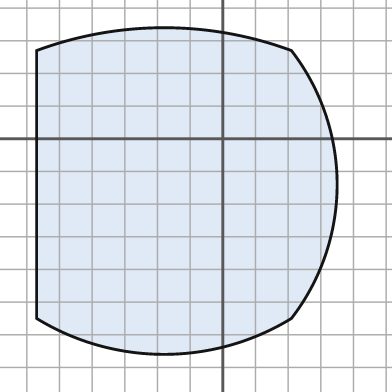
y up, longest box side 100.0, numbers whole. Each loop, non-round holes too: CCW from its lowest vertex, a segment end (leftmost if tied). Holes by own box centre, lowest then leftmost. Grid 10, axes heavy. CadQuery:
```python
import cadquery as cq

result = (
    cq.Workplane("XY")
    .moveTo(-57.0, -55.0)
    .threePointArc((-18.0, -66.0), (21.0, -55.0))
    .threePointArc((35.0, -14.0), (21.0, 27.0))
    .threePointArc((-18.0, 34.0), (-57.0, 27.0))
    .close()
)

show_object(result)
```